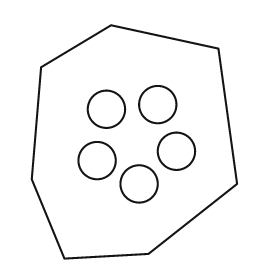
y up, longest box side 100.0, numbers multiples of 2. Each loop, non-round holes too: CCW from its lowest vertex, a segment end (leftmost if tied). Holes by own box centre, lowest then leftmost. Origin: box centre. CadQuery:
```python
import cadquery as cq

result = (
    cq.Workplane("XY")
    .moveTo(-30.0, -50.0)
    .lineTo(6.0, -48.0)
    .lineTo(44.0, -18.0)
    .lineTo(36.0, 40.0)
    .lineTo(-10.0, 50.0)
    .lineTo(-40.0, 32.0)
    .lineTo(-44.0, -16.0)
    .close()
    .moveTo(2.0, -18.0)
    .circle(8.0)
    .moveTo(-16.0, -8.0)
    .circle(8.0)
    .moveTo(18.0, -4.0)
    .circle(8.0)
    .moveTo(-12.0, 14.0)
    .circle(8.0)
    .moveTo(10.0, 16.0)
    .circle(8.0)
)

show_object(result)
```